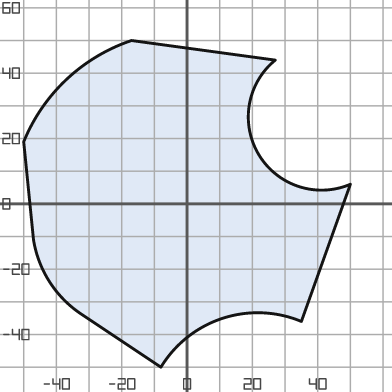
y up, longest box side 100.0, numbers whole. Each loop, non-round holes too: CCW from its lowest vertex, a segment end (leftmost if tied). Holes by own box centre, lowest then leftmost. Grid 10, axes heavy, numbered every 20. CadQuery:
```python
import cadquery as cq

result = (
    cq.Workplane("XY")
    .moveTo(-8.0, -50.0)
    .threePointArc((11.0, -35.0), (35.0, -36.0))
    .lineTo(50.0, 6.0)
    .threePointArc((22.0, 15.0), (27.0, 44.0))
    .lineTo(-17.0, 50.0)
    .threePointArc((-37.0, 38.0), (-50.0, 19.0))
    .lineTo(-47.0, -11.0)
    .threePointArc((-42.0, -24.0), (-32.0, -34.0))
    .close()
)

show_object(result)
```